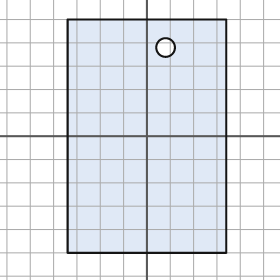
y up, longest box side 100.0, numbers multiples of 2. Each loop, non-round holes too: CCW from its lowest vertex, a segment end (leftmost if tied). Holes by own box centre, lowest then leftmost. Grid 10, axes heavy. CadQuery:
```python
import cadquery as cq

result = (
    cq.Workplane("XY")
    .moveTo(-34.0, -50.0)
    .lineTo(34.0, -50.0)
    .lineTo(34.0, 50.0)
    .lineTo(-34.0, 50.0)
    .close()
    .moveTo(8.0, 38.0)
    .circle(4.0)
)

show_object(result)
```